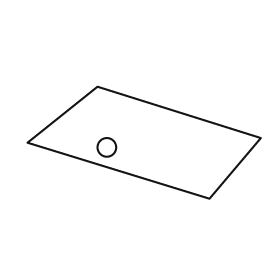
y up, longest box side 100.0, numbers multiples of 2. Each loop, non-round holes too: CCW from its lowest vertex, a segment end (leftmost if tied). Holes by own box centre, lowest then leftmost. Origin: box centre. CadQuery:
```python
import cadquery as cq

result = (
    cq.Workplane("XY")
    .moveTo(28.0, -24.0)
    .lineTo(50.0, 2.0)
    .lineTo(-20.0, 24.0)
    .lineTo(-50.0, 0.0)
    .close()
    .moveTo(-16.0, -2.0)
    .circle(4.0)
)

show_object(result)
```